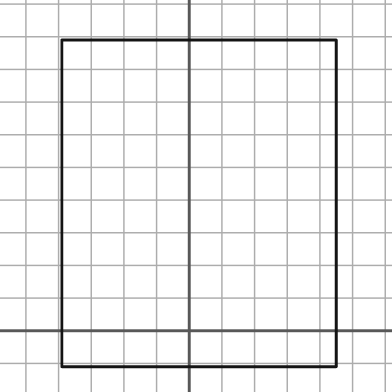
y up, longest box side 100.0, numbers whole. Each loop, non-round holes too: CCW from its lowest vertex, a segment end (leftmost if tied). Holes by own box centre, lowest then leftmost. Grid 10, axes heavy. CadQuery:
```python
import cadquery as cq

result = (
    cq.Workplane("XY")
    .moveTo(-39.0, -11.0)
    .lineTo(45.0, -11.0)
    .lineTo(45.0, 89.0)
    .lineTo(-39.0, 89.0)
    .close()
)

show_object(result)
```